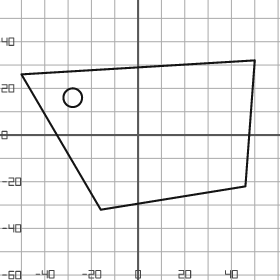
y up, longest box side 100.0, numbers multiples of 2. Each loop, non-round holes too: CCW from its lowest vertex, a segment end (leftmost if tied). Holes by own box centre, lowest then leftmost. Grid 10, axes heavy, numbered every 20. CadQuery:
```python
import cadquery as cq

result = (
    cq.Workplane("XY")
    .moveTo(-16.0, -32.0)
    .lineTo(46.0, -22.0)
    .lineTo(50.0, 32.0)
    .lineTo(-50.0, 26.0)
    .close()
    .moveTo(-28.0, 16.0)
    .circle(4.0)
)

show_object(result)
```